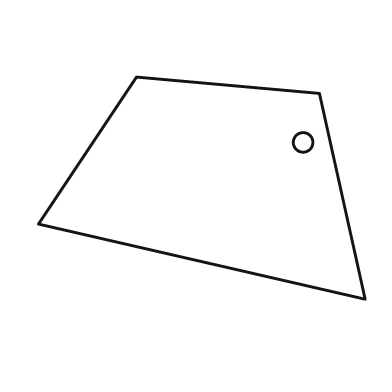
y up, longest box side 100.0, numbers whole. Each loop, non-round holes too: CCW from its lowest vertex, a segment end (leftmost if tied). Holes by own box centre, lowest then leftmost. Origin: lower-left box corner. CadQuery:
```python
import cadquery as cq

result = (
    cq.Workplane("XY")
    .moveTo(100.0, 0.0)
    .lineTo(86.0, 63.0)
    .lineTo(30.0, 68.0)
    .lineTo(0.0, 23.0)
    .close()
    .moveTo(81.0, 48.0)
    .circle(3.0)
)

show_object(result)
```